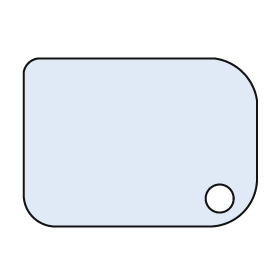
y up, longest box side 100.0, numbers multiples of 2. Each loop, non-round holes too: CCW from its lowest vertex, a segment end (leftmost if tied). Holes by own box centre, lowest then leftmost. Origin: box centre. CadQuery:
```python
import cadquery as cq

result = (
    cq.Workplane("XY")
    .moveTo(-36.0, -36.0)
    .lineTo(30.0, -36.0)
    .threePointArc((44.0, -30.0), (50.0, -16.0))
    .lineTo(50.0, 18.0)
    .threePointArc((44.0, 30.0), (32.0, 36.0))
    .lineTo(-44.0, 36.0)
    .threePointArc((-48.0, 34.0), (-50.0, 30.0))
    .lineTo(-50.0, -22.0)
    .threePointArc((-46.0, -32.0), (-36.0, -36.0))
    .close()
    .moveTo(34.0, -24.0)
    .circle(6.0)
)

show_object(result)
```